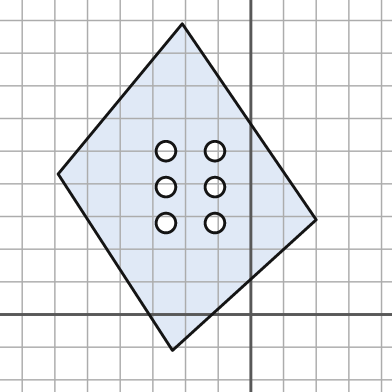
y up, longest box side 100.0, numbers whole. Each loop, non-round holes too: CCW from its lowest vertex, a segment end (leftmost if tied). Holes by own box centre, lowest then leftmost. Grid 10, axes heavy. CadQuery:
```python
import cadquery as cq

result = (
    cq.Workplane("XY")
    .moveTo(-24.0, -11.0)
    .lineTo(20.0, 29.0)
    .lineTo(-21.0, 89.0)
    .lineTo(-59.0, 43.0)
    .close()
    .moveTo(-26.0, 28.0)
    .circle(3.0)
    .moveTo(-11.0, 28.0)
    .circle(3.0)
    .moveTo(-26.0, 39.0)
    .circle(3.0)
    .moveTo(-11.0, 39.0)
    .circle(3.0)
    .moveTo(-26.0, 50.0)
    .circle(3.0)
    .moveTo(-11.0, 50.0)
    .circle(3.0)
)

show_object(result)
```